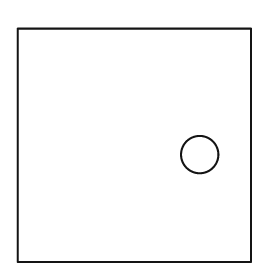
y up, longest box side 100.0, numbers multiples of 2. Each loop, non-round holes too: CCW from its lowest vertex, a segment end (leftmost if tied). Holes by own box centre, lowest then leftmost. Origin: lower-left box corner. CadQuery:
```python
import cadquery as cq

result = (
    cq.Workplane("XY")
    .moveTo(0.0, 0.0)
    .lineTo(100.0, 0.0)
    .lineTo(100.0, 100.0)
    .lineTo(0.0, 100.0)
    .close()
    .moveTo(78.0, 46.0)
    .circle(8.0)
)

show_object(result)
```